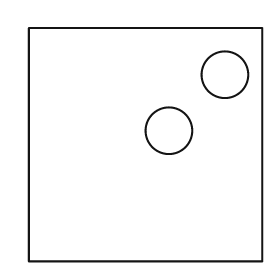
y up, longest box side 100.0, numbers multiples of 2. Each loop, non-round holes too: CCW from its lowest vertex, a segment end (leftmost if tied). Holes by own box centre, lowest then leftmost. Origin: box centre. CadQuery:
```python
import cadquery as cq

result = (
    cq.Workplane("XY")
    .moveTo(-50.0, -50.0)
    .lineTo(50.0, -50.0)
    .lineTo(50.0, 50.0)
    .lineTo(-50.0, 50.0)
    .close()
    .moveTo(10.0, 6.0)
    .circle(10.0)
    .moveTo(34.0, 30.0)
    .circle(10.0)
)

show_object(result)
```